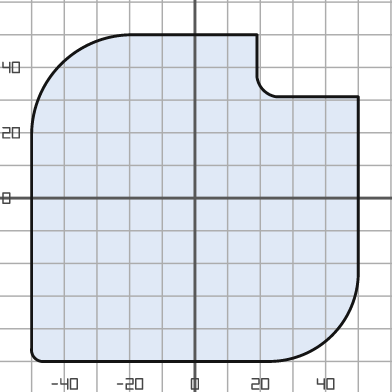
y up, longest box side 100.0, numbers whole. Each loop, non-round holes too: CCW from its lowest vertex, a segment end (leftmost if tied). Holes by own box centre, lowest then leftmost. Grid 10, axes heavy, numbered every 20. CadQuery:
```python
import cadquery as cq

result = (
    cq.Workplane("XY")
    .moveTo(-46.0, -50.0)
    .lineTo(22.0, -50.0)
    .threePointArc((42.0, -42.0), (50.0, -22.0))
    .lineTo(50.0, 31.0)
    .lineTo(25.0, 31.0)
    .threePointArc((21.0, 33.0), (19.0, 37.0))
    .lineTo(19.0, 50.0)
    .lineTo(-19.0, 50.0)
    .threePointArc((-41.0, 41.0), (-50.0, 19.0))
    .lineTo(-50.0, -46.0)
    .threePointArc((-49.0, -49.0), (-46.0, -50.0))
    .close()
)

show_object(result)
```